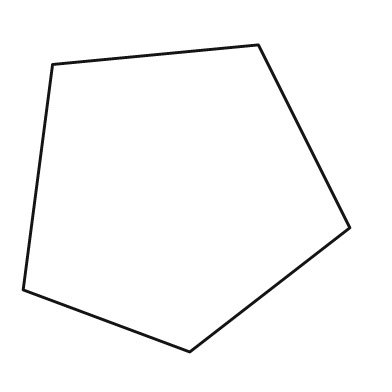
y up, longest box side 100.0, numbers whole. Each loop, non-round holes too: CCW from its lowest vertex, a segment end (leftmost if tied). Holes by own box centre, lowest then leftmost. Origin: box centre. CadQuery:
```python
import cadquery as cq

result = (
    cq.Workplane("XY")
    .moveTo(1.0, -47.0)
    .lineTo(50.0, -9.0)
    .lineTo(22.0, 47.0)
    .lineTo(-41.0, 41.0)
    .lineTo(-50.0, -28.0)
    .close()
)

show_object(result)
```